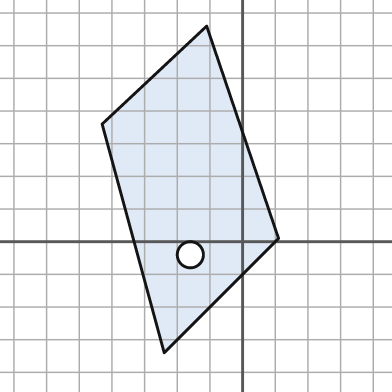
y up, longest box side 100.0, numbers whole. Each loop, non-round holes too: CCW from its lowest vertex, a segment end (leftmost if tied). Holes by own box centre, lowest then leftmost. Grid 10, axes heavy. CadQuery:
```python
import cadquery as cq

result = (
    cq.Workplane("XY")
    .moveTo(-24.0, -34.0)
    .lineTo(11.0, 1.0)
    .lineTo(-11.0, 66.0)
    .lineTo(-43.0, 36.0)
    .close()
    .moveTo(-16.0, -4.0)
    .circle(4.0)
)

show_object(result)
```